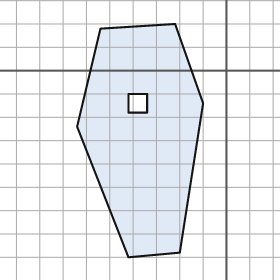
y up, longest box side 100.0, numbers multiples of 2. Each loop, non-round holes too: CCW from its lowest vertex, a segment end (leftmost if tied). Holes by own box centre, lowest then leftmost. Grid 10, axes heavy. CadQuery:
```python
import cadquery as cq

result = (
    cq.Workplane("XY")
    .moveTo(-42.0, -80.0)
    .lineTo(-20.0, -78.0)
    .lineTo(-10.0, -14.0)
    .lineTo(-22.0, 20.0)
    .lineTo(-54.0, 18.0)
    .lineTo(-64.0, -24.0)
    .close()
    .moveTo(-42.0, -18.0)
    .lineTo(-34.0, -18.0)
    .lineTo(-34.0, -10.0)
    .lineTo(-42.0, -10.0)
    .close()
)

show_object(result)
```